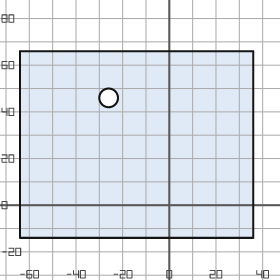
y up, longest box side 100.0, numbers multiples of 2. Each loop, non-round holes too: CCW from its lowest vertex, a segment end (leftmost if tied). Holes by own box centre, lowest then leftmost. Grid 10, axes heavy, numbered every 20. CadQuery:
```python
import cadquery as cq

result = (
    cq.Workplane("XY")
    .moveTo(-64.0, -14.0)
    .lineTo(36.0, -14.0)
    .lineTo(36.0, 66.0)
    .lineTo(-64.0, 66.0)
    .close()
    .moveTo(-26.0, 46.0)
    .circle(4.0)
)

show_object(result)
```